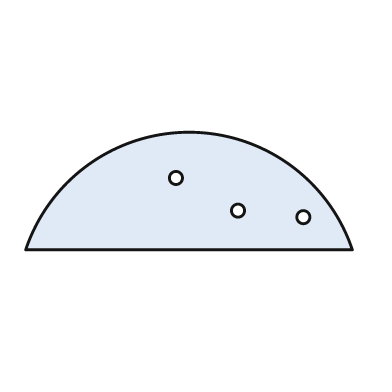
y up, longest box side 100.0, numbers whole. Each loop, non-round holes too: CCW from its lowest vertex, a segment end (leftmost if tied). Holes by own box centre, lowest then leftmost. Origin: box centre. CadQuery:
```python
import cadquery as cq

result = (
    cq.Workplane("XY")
    .moveTo(-50.0, -18.0)
    .lineTo(50.0, -18.0)
    .threePointArc((0.0, 18.0), (-50.0, -18.0))
    .close()
    .moveTo(35.0, -8.0)
    .circle(2.0)
    .moveTo(15.0, -6.0)
    .circle(2.0)
    .moveTo(-4.0, 4.0)
    .circle(2.0)
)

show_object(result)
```